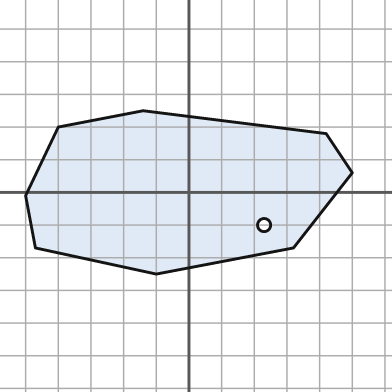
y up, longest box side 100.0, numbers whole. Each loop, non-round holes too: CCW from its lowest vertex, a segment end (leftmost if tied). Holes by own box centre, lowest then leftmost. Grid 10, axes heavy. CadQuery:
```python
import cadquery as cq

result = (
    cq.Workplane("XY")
    .moveTo(-10.0, -25.0)
    .lineTo(32.0, -17.0)
    .lineTo(50.0, 6.0)
    .lineTo(42.0, 18.0)
    .lineTo(-14.0, 25.0)
    .lineTo(-40.0, 20.0)
    .lineTo(-50.0, -1.0)
    .lineTo(-47.0, -17.0)
    .close()
    .moveTo(23.0, -10.0)
    .circle(2.0)
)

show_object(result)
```